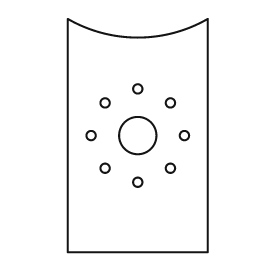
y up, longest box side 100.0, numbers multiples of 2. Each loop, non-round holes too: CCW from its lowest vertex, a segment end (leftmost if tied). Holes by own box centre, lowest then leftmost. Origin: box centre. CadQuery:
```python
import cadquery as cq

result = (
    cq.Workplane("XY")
    .moveTo(-30.0, -50.0)
    .lineTo(30.0, -50.0)
    .lineTo(30.0, 50.0)
    .threePointArc((0.0, 42.0), (-30.0, 50.0))
    .close()
    .moveTo(0.0, -20.0)
    .circle(2.0)
    .moveTo(-14.0, -14.0)
    .circle(2.0)
    .moveTo(14.0, -14.0)
    .circle(2.0)
    .moveTo(-20.0, 0.0)
    .circle(2.0)
    .moveTo(0.0, 0.0)
    .circle(8.0)
    .moveTo(20.0, 0.0)
    .circle(2.0)
    .moveTo(-14.0, 14.0)
    .circle(2.0)
    .moveTo(14.0, 14.0)
    .circle(2.0)
    .moveTo(0.0, 20.0)
    .circle(2.0)
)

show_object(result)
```